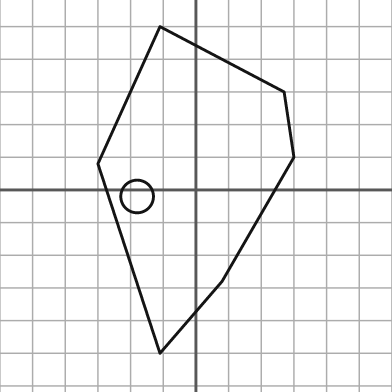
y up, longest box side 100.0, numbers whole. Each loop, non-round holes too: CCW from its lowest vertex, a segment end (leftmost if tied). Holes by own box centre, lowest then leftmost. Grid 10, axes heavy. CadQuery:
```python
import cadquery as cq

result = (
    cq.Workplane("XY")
    .moveTo(-11.0, -50.0)
    .lineTo(8.0, -28.0)
    .lineTo(30.0, 10.0)
    .lineTo(27.0, 30.0)
    .lineTo(-11.0, 50.0)
    .lineTo(-30.0, 8.0)
    .close()
    .moveTo(-18.0, -2.0)
    .circle(5.0)
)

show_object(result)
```